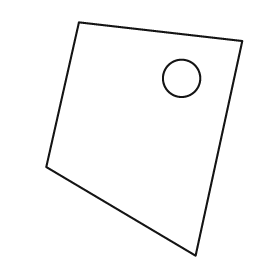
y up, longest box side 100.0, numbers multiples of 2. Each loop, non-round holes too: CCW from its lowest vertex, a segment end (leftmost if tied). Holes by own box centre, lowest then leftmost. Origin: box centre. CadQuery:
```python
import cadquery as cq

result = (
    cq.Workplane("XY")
    .moveTo(22.0, -50.0)
    .lineTo(42.0, 42.0)
    .lineTo(-28.0, 50.0)
    .lineTo(-42.0, -12.0)
    .close()
    .moveTo(16.0, 26.0)
    .circle(8.0)
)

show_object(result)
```